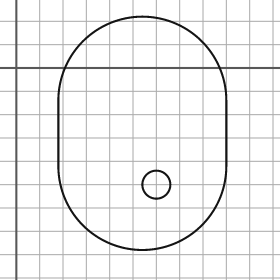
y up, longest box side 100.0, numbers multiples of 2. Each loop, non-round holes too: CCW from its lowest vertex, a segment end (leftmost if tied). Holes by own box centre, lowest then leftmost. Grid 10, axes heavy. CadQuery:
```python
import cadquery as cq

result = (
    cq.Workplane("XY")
    .moveTo(18.0, -42.0)
    .threePointArc((54.0, -78.0), (90.0, -42.0))
    .lineTo(90.0, -14.0)
    .threePointArc((54.0, 22.0), (18.0, -14.0))
    .close()
    .moveTo(60.0, -50.0)
    .circle(6.0)
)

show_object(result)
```